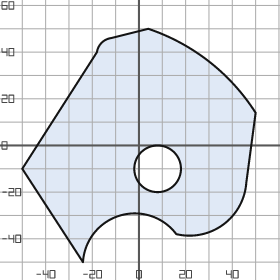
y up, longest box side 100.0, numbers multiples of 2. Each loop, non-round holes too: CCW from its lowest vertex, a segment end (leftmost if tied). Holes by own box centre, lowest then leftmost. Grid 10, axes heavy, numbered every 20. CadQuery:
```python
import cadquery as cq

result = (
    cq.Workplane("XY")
    .moveTo(-24.0, -50.0)
    .threePointArc((-8.0, -30.0), (16.0, -38.0))
    .threePointArc((36.0, -34.0), (46.0, -16.0))
    .lineTo(50.0, 14.0)
    .threePointArc((30.0, 36.0), (4.0, 50.0))
    .lineTo(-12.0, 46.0)
    .threePointArc((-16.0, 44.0), (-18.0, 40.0))
    .lineTo(-50.0, -10.0)
    .close()
    .moveTo(8.0, -10.0)
    .circle(10.0)
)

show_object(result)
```